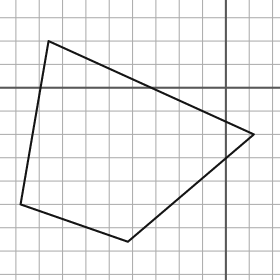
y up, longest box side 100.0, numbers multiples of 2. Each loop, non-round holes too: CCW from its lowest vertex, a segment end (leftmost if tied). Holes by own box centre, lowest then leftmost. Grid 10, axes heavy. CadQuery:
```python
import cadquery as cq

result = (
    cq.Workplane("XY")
    .moveTo(-42.0, -66.0)
    .lineTo(12.0, -20.0)
    .lineTo(-76.0, 20.0)
    .lineTo(-88.0, -50.0)
    .close()
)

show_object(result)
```